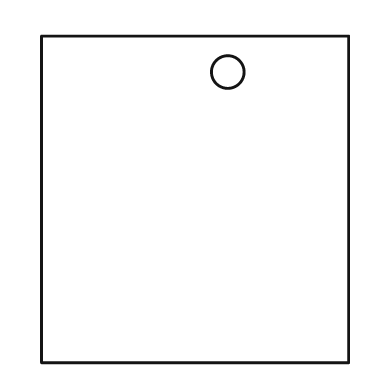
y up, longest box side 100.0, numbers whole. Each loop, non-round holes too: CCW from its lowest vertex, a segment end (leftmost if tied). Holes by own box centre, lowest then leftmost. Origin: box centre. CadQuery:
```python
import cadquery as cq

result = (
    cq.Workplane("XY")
    .moveTo(-47.0, -50.0)
    .lineTo(47.0, -50.0)
    .lineTo(47.0, 50.0)
    .lineTo(-47.0, 50.0)
    .close()
    .moveTo(10.0, 39.0)
    .circle(5.0)
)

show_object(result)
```